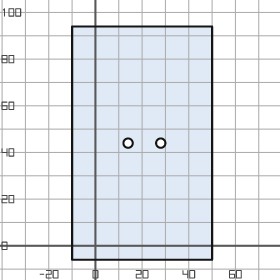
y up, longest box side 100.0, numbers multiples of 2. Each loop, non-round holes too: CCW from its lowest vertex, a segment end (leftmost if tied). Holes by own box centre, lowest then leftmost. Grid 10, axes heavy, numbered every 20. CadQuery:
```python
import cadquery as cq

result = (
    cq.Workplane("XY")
    .moveTo(-10.0, -6.0)
    .lineTo(50.0, -6.0)
    .lineTo(50.0, 94.0)
    .lineTo(-10.0, 94.0)
    .close()
    .moveTo(14.0, 44.0)
    .circle(2.0)
    .moveTo(28.0, 44.0)
    .circle(2.0)
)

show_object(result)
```